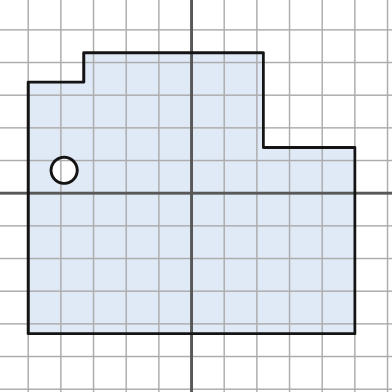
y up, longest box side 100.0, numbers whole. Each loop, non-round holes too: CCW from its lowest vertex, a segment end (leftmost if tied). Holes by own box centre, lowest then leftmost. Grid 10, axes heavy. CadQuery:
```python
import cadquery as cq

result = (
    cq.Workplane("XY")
    .moveTo(-50.0, -43.0)
    .lineTo(50.0, -43.0)
    .lineTo(50.0, 14.0)
    .lineTo(22.0, 14.0)
    .lineTo(22.0, 43.0)
    .lineTo(-33.0, 43.0)
    .lineTo(-33.0, 34.0)
    .lineTo(-50.0, 34.0)
    .close()
    .moveTo(-39.0, 7.0)
    .circle(4.0)
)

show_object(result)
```